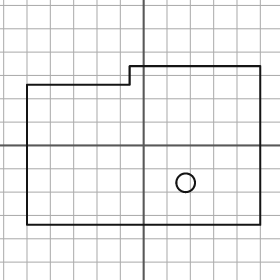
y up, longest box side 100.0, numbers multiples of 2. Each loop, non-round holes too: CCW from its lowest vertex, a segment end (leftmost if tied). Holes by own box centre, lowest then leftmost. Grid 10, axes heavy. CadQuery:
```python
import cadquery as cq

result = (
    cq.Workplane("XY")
    .moveTo(-50.0, -34.0)
    .lineTo(50.0, -34.0)
    .lineTo(50.0, 34.0)
    .lineTo(-6.0, 34.0)
    .lineTo(-6.0, 26.0)
    .lineTo(-50.0, 26.0)
    .close()
    .moveTo(18.0, -16.0)
    .circle(4.0)
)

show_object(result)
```